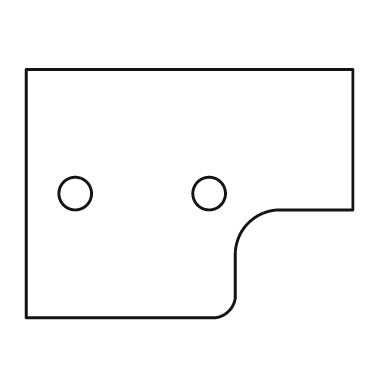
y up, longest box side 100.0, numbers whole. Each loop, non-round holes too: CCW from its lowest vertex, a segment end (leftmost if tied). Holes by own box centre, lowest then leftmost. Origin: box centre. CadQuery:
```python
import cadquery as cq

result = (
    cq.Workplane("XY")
    .moveTo(-50.0, -38.0)
    .lineTo(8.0, -38.0)
    .threePointArc((12.0, -36.0), (14.0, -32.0))
    .lineTo(14.0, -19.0)
    .threePointArc((18.0, -9.0), (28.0, -5.0))
    .lineTo(50.0, -5.0)
    .lineTo(50.0, 38.0)
    .lineTo(-50.0, 38.0)
    .close()
    .moveTo(-35.0, 0.0)
    .circle(5.0)
    .moveTo(6.0, 0.0)
    .circle(5.0)
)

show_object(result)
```